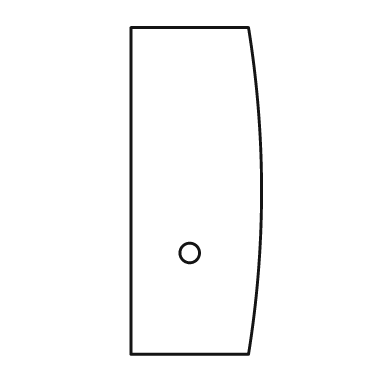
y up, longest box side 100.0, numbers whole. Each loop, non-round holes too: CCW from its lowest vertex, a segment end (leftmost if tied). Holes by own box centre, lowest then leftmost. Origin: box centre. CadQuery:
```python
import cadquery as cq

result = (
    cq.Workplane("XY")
    .moveTo(-20.0, -50.0)
    .lineTo(16.0, -50.0)
    .threePointArc((20.0, 0.0), (16.0, 50.0))
    .lineTo(-20.0, 50.0)
    .close()
    .moveTo(-2.0, -19.0)
    .circle(3.0)
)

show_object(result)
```